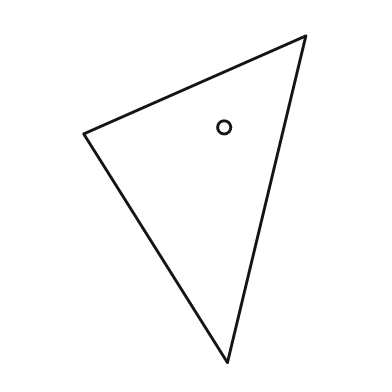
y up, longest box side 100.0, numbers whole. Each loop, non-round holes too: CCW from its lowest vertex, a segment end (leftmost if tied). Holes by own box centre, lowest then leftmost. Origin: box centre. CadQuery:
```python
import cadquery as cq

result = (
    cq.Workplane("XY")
    .moveTo(10.0, -50.0)
    .lineTo(34.0, 50.0)
    .lineTo(-34.0, 20.0)
    .close()
    .moveTo(9.0, 22.0)
    .circle(2.0)
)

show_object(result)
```